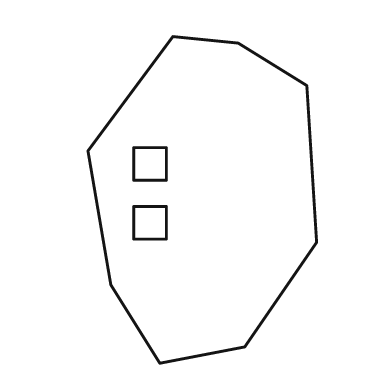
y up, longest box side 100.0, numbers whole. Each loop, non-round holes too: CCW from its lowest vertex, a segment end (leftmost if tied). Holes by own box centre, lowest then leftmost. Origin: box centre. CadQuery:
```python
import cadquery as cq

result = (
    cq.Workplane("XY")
    .moveTo(-13.0, -50.0)
    .lineTo(13.0, -45.0)
    .lineTo(35.0, -13.0)
    .lineTo(32.0, 35.0)
    .lineTo(11.0, 48.0)
    .lineTo(-9.0, 50.0)
    .lineTo(-35.0, 15.0)
    .lineTo(-28.0, -26.0)
    .close()
    .moveTo(-21.0, -12.0)
    .lineTo(-11.0, -12.0)
    .lineTo(-11.0, -2.0)
    .lineTo(-21.0, -2.0)
    .close()
    .moveTo(-21.0, 6.0)
    .lineTo(-11.0, 6.0)
    .lineTo(-11.0, 16.0)
    .lineTo(-21.0, 16.0)
    .close()
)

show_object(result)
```